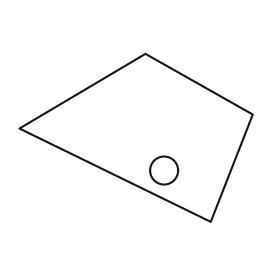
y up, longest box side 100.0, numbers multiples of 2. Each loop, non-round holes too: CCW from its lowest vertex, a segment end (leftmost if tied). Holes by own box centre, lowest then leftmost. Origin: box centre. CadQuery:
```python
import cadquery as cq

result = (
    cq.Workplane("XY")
    .moveTo(32.0, -36.0)
    .lineTo(50.0, 10.0)
    .lineTo(4.0, 36.0)
    .lineTo(-50.0, 4.0)
    .close()
    .moveTo(12.0, -14.0)
    .circle(6.0)
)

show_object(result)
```